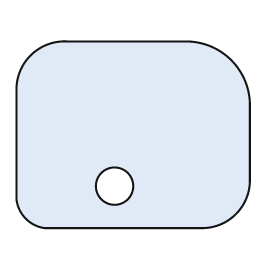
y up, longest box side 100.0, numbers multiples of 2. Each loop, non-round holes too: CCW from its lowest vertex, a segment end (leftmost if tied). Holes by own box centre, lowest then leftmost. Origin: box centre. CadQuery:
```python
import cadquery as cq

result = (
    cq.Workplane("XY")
    .moveTo(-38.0, -40.0)
    .lineTo(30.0, -40.0)
    .threePointArc((44.0, -34.0), (50.0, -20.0))
    .lineTo(50.0, 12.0)
    .threePointArc((42.0, 32.0), (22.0, 40.0))
    .lineTo(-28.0, 40.0)
    .threePointArc((-44.0, 34.0), (-50.0, 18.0))
    .lineTo(-50.0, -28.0)
    .threePointArc((-46.0, -36.0), (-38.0, -40.0))
    .close()
    .moveTo(-8.0, -22.0)
    .circle(8.0)
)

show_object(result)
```